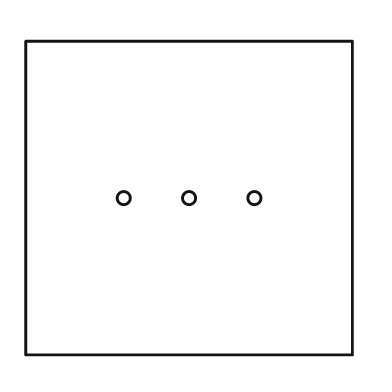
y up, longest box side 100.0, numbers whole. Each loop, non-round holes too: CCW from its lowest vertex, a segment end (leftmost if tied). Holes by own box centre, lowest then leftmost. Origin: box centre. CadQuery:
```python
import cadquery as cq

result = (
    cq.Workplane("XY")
    .moveTo(-50.0, -48.0)
    .lineTo(50.0, -48.0)
    .lineTo(50.0, 48.0)
    .lineTo(-50.0, 48.0)
    .close()
    .moveTo(-20.0, 0.0)
    .circle(2.0)
    .moveTo(0.0, 0.0)
    .circle(2.0)
    .moveTo(20.0, 0.0)
    .circle(2.0)
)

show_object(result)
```